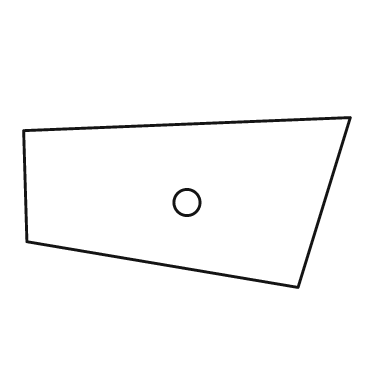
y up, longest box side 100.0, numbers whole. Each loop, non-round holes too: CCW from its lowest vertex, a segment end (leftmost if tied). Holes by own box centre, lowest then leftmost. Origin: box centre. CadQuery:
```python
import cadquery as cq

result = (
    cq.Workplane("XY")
    .moveTo(34.0, -26.0)
    .lineTo(50.0, 26.0)
    .lineTo(-50.0, 22.0)
    .lineTo(-49.0, -12.0)
    .close()
    .moveTo(0.0, 0.0)
    .circle(4.0)
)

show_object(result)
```